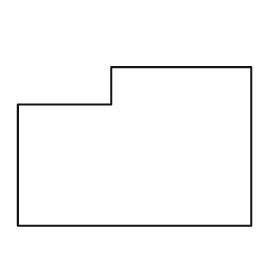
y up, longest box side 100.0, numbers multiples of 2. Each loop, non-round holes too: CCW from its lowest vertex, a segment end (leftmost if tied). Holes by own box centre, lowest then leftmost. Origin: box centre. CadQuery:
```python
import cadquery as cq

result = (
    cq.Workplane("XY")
    .moveTo(-50.0, -34.0)
    .lineTo(50.0, -34.0)
    .lineTo(50.0, 34.0)
    .lineTo(-10.0, 34.0)
    .lineTo(-10.0, 18.0)
    .lineTo(-50.0, 18.0)
    .close()
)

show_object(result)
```